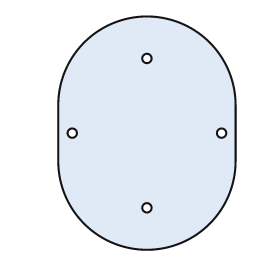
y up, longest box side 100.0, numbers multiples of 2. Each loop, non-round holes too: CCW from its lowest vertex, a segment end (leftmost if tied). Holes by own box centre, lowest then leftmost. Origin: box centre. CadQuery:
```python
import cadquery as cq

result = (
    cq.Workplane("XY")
    .moveTo(-38.0, -12.0)
    .threePointArc((0.0, -50.0), (38.0, -12.0))
    .lineTo(38.0, 12.0)
    .threePointArc((0.0, 50.0), (-38.0, 12.0))
    .close()
    .moveTo(0.0, -32.0)
    .circle(2.0)
    .moveTo(-32.0, 0.0)
    .circle(2.0)
    .moveTo(32.0, 0.0)
    .circle(2.0)
    .moveTo(0.0, 32.0)
    .circle(2.0)
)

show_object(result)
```